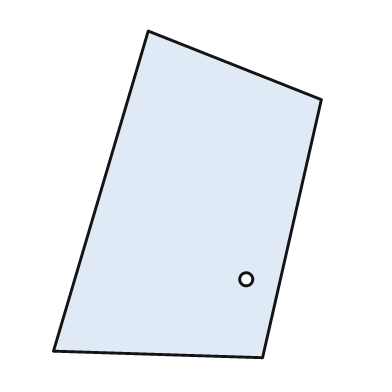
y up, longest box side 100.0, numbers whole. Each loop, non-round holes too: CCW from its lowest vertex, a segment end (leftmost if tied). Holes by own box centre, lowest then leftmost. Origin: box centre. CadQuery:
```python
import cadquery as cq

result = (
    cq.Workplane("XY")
    .moveTo(23.0, -50.0)
    .lineTo(41.0, 29.0)
    .lineTo(-12.0, 50.0)
    .lineTo(-41.0, -48.0)
    .close()
    .moveTo(18.0, -26.0)
    .circle(2.0)
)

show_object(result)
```